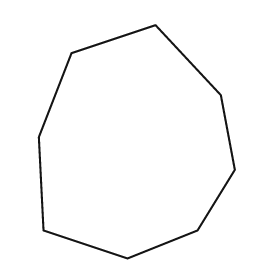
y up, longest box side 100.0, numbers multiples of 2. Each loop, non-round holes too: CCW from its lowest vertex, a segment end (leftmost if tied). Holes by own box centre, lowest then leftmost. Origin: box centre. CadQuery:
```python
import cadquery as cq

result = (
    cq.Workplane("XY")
    .moveTo(-4.0, -50.0)
    .lineTo(26.0, -38.0)
    .lineTo(42.0, -12.0)
    .lineTo(36.0, 20.0)
    .lineTo(8.0, 50.0)
    .lineTo(-28.0, 38.0)
    .lineTo(-42.0, 2.0)
    .lineTo(-40.0, -38.0)
    .close()
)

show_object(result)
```